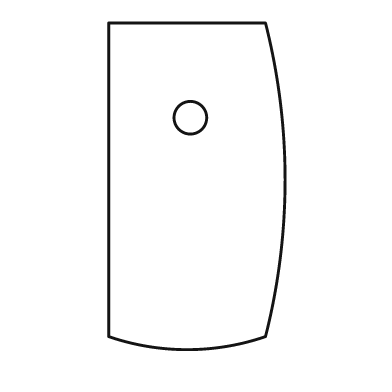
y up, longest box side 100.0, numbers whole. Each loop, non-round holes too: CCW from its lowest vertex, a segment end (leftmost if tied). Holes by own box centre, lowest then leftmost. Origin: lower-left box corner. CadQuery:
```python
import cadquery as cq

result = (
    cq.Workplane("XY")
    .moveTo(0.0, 4.0)
    .threePointArc((24.0, 0.0), (48.0, 4.0))
    .threePointArc((54.0, 52.0), (48.0, 100.0))
    .lineTo(0.0, 100.0)
    .close()
    .moveTo(25.0, 71.0)
    .circle(5.0)
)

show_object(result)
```